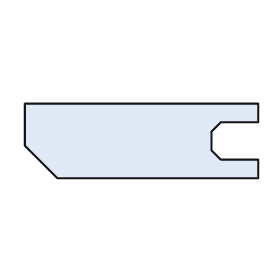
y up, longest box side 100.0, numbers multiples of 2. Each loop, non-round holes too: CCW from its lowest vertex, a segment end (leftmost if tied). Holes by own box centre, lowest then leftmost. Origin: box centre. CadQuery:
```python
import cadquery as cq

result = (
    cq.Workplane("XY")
    .moveTo(-36.0, -16.0)
    .lineTo(50.0, -16.0)
    .lineTo(50.0, -8.0)
    .lineTo(34.0, -8.0)
    .lineTo(30.0, -4.0)
    .lineTo(30.0, 4.0)
    .lineTo(34.0, 8.0)
    .lineTo(50.0, 8.0)
    .lineTo(50.0, 16.0)
    .lineTo(-50.0, 16.0)
    .lineTo(-50.0, -2.0)
    .close()
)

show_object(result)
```